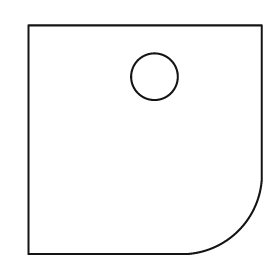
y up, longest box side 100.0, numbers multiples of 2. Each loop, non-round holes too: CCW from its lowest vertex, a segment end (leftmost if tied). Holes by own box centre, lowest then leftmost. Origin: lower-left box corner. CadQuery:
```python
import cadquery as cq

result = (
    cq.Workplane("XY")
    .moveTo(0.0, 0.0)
    .lineTo(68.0, 0.0)
    .threePointArc((90.0, 10.0), (100.0, 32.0))
    .lineTo(100.0, 98.0)
    .lineTo(0.0, 98.0)
    .close()
    .moveTo(54.0, 76.0)
    .circle(10.0)
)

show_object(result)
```